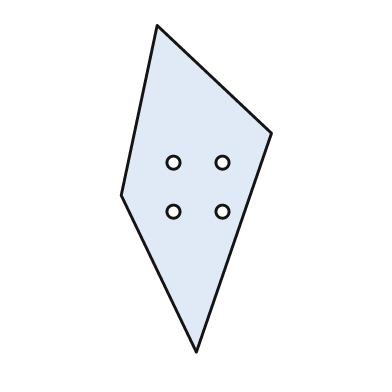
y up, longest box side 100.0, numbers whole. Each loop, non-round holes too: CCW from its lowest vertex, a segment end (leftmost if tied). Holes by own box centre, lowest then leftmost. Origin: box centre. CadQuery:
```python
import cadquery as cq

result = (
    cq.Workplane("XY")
    .moveTo(0.0, -50.0)
    .lineTo(23.0, 17.0)
    .lineTo(-12.0, 50.0)
    .lineTo(-23.0, -2.0)
    .close()
    .moveTo(-7.0, -7.0)
    .circle(2.0)
    .moveTo(8.0, -7.0)
    .circle(2.0)
    .moveTo(-7.0, 8.0)
    .circle(2.0)
    .moveTo(8.0, 8.0)
    .circle(2.0)
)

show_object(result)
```